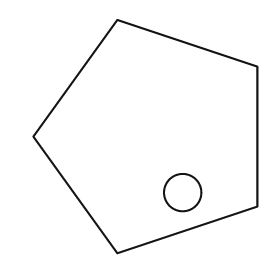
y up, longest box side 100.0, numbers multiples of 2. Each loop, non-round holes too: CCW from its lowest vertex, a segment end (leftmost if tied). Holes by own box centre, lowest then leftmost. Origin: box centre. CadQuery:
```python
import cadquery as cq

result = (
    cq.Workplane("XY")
    .moveTo(-12.0, -50.0)
    .lineTo(48.0, -30.0)
    .lineTo(48.0, 30.0)
    .lineTo(-12.0, 50.0)
    .lineTo(-48.0, 0.0)
    .close()
    .moveTo(16.0, -24.0)
    .circle(8.0)
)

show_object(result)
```